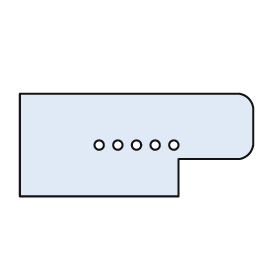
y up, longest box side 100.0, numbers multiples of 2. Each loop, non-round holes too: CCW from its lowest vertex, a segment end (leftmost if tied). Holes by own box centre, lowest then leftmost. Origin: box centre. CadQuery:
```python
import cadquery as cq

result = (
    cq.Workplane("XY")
    .moveTo(-50.0, -22.0)
    .lineTo(18.0, -22.0)
    .lineTo(18.0, -6.0)
    .lineTo(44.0, -6.0)
    .threePointArc((48.0, -4.0), (50.0, 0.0))
    .lineTo(50.0, 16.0)
    .threePointArc((48.0, 20.0), (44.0, 22.0))
    .lineTo(-50.0, 22.0)
    .close()
    .moveTo(-16.0, 0.0)
    .circle(2.0)
    .moveTo(-8.0, 0.0)
    .circle(2.0)
    .moveTo(0.0, 0.0)
    .circle(2.0)
    .moveTo(8.0, 0.0)
    .circle(2.0)
    .moveTo(16.0, 0.0)
    .circle(2.0)
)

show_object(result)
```